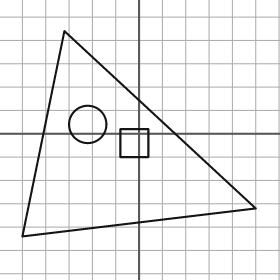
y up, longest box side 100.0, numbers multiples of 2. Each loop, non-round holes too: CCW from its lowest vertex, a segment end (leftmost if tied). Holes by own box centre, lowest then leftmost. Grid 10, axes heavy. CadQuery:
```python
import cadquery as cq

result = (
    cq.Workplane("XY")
    .moveTo(-50.0, -44.0)
    .lineTo(50.0, -32.0)
    .lineTo(-32.0, 44.0)
    .close()
    .moveTo(-8.0, -10.0)
    .lineTo(4.0, -10.0)
    .lineTo(4.0, 2.0)
    .lineTo(-8.0, 2.0)
    .close()
    .moveTo(-22.0, 4.0)
    .circle(8.0)
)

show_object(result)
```